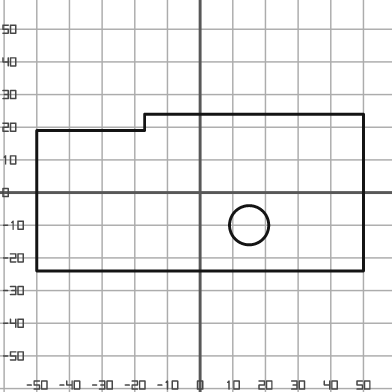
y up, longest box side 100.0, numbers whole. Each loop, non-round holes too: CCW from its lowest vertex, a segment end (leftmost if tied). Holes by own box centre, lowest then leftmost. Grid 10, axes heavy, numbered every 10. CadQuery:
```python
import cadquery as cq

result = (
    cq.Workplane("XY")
    .moveTo(-50.0, -24.0)
    .lineTo(50.0, -24.0)
    .lineTo(50.0, 24.0)
    .lineTo(-17.0, 24.0)
    .lineTo(-17.0, 19.0)
    .lineTo(-50.0, 19.0)
    .close()
    .moveTo(15.0, -10.0)
    .circle(6.0)
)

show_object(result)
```